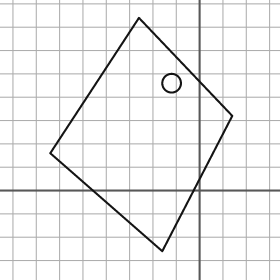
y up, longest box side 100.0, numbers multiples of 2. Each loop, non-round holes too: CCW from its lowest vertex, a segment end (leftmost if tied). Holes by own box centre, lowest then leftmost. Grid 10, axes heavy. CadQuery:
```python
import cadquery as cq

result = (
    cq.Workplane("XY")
    .moveTo(-16.0, -26.0)
    .lineTo(14.0, 32.0)
    .lineTo(-26.0, 74.0)
    .lineTo(-64.0, 16.0)
    .close()
    .moveTo(-12.0, 46.0)
    .circle(4.0)
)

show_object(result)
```